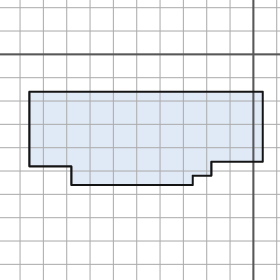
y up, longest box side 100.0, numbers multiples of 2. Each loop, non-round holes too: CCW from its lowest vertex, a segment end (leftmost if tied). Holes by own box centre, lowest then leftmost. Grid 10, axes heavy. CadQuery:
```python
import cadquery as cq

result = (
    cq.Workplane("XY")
    .moveTo(-78.0, -56.0)
    .lineTo(-26.0, -56.0)
    .lineTo(-26.0, -52.0)
    .lineTo(-18.0, -52.0)
    .lineTo(-18.0, -46.0)
    .lineTo(4.0, -46.0)
    .lineTo(4.0, -16.0)
    .lineTo(-96.0, -16.0)
    .lineTo(-96.0, -48.0)
    .lineTo(-78.0, -48.0)
    .close()
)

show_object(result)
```